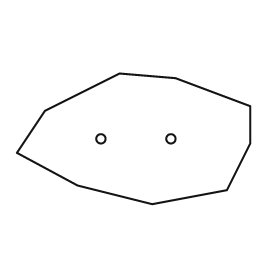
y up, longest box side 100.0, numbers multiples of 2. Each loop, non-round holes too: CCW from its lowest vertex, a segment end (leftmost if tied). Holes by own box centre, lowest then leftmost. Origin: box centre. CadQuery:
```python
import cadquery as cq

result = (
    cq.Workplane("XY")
    .moveTo(8.0, -28.0)
    .lineTo(40.0, -22.0)
    .lineTo(50.0, -2.0)
    .lineTo(50.0, 14.0)
    .lineTo(18.0, 26.0)
    .lineTo(-6.0, 28.0)
    .lineTo(-38.0, 12.0)
    .lineTo(-50.0, -6.0)
    .lineTo(-24.0, -20.0)
    .close()
    .moveTo(-14.0, 0.0)
    .circle(2.0)
    .moveTo(16.0, 0.0)
    .circle(2.0)
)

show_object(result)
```